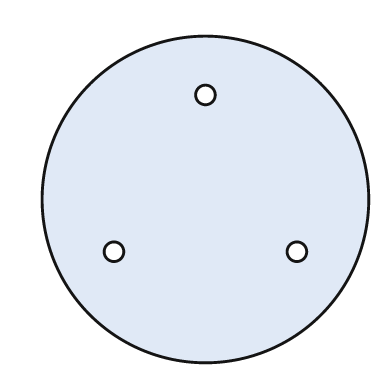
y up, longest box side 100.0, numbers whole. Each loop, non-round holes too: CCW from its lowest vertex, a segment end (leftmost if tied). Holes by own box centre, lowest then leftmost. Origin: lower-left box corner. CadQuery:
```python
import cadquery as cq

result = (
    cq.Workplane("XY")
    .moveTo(50.0, 50.0)
    .circle(50.0)
    .moveTo(22.0, 34.0)
    .circle(3.0)
    .moveTo(78.0, 34.0)
    .circle(3.0)
    .moveTo(50.0, 82.0)
    .circle(3.0)
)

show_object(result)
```